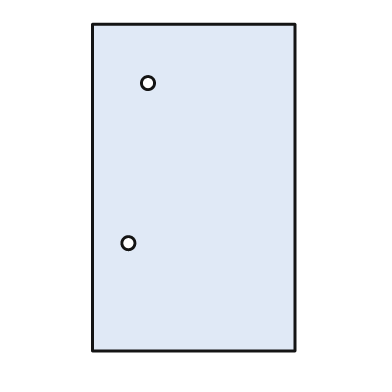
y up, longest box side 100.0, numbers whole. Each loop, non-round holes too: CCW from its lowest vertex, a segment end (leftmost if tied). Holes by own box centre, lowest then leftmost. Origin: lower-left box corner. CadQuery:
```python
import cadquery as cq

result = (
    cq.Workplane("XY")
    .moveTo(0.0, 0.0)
    .lineTo(62.0, 0.0)
    .lineTo(62.0, 100.0)
    .lineTo(0.0, 100.0)
    .close()
    .moveTo(11.0, 33.0)
    .circle(2.0)
    .moveTo(17.0, 82.0)
    .circle(2.0)
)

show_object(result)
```